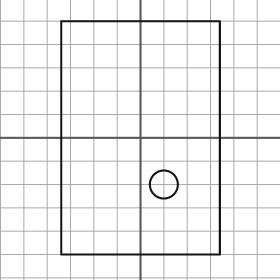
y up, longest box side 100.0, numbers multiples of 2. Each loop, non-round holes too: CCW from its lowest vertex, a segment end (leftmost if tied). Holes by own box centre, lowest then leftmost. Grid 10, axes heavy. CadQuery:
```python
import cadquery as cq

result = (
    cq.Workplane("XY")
    .moveTo(-34.0, -50.0)
    .lineTo(34.0, -50.0)
    .lineTo(34.0, 50.0)
    .lineTo(-34.0, 50.0)
    .close()
    .moveTo(10.0, -20.0)
    .circle(6.0)
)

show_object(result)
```